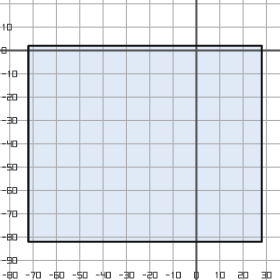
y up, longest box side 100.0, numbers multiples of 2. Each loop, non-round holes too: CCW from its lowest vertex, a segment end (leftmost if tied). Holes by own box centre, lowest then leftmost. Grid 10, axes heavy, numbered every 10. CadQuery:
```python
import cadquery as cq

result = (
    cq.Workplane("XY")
    .moveTo(-72.0, -82.0)
    .lineTo(28.0, -82.0)
    .lineTo(28.0, 2.0)
    .lineTo(-72.0, 2.0)
    .close()
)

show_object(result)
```